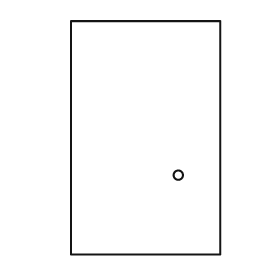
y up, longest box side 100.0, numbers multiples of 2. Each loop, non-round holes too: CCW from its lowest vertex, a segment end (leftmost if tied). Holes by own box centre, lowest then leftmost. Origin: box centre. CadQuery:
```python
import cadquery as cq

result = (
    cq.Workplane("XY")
    .moveTo(-32.0, -50.0)
    .lineTo(32.0, -50.0)
    .lineTo(32.0, 50.0)
    .lineTo(-32.0, 50.0)
    .close()
    .moveTo(14.0, -16.0)
    .circle(2.0)
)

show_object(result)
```